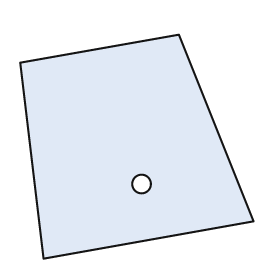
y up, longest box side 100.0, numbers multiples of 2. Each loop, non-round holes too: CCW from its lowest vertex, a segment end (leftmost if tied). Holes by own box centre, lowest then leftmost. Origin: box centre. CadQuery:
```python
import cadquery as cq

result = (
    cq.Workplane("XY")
    .moveTo(-40.0, -48.0)
    .lineTo(50.0, -32.0)
    .lineTo(18.0, 48.0)
    .lineTo(-50.0, 36.0)
    .close()
    .moveTo(2.0, -16.0)
    .circle(4.0)
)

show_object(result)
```